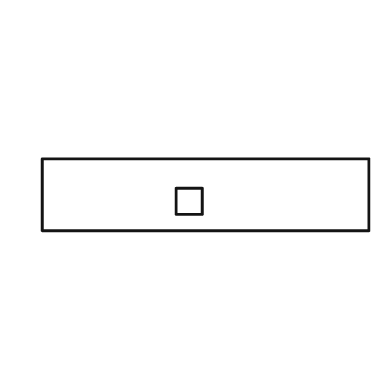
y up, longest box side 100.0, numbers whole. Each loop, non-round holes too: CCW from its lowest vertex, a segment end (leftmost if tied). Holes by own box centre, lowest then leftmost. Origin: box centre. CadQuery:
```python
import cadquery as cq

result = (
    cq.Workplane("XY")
    .moveTo(-50.0, -11.0)
    .lineTo(50.0, -11.0)
    .lineTo(50.0, 11.0)
    .lineTo(-50.0, 11.0)
    .close()
    .moveTo(-9.0, -6.0)
    .lineTo(-1.0, -6.0)
    .lineTo(-1.0, 2.0)
    .lineTo(-9.0, 2.0)
    .close()
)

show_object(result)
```